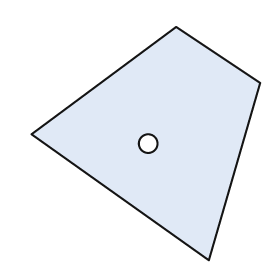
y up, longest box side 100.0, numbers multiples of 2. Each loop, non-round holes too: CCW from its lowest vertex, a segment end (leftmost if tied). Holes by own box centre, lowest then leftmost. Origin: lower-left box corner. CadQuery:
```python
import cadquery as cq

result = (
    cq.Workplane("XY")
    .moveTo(76.0, 0.0)
    .lineTo(98.0, 76.0)
    .lineTo(62.0, 100.0)
    .lineTo(0.0, 54.0)
    .close()
    .moveTo(50.0, 50.0)
    .circle(4.0)
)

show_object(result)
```